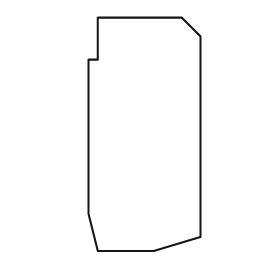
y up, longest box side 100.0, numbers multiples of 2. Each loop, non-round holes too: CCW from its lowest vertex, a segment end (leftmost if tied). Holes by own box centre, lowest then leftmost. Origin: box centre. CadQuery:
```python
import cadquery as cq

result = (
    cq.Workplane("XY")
    .moveTo(-20.0, -50.0)
    .lineTo(4.0, -50.0)
    .lineTo(24.0, -44.0)
    .lineTo(24.0, 42.0)
    .lineTo(16.0, 50.0)
    .lineTo(-20.0, 50.0)
    .lineTo(-20.0, 32.0)
    .lineTo(-24.0, 32.0)
    .lineTo(-24.0, -34.0)
    .close()
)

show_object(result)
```